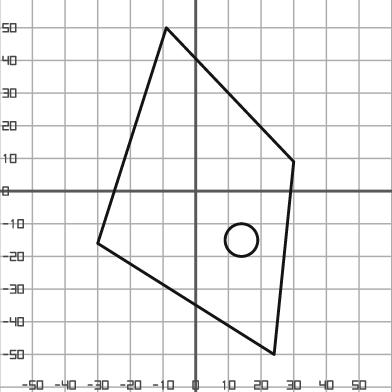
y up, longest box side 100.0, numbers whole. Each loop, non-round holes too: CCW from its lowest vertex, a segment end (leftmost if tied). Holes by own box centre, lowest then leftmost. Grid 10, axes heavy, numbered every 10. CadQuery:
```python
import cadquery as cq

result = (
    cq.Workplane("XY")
    .moveTo(24.0, -50.0)
    .lineTo(30.0, 9.0)
    .lineTo(-9.0, 50.0)
    .lineTo(-30.0, -16.0)
    .close()
    .moveTo(14.0, -15.0)
    .circle(5.0)
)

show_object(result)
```